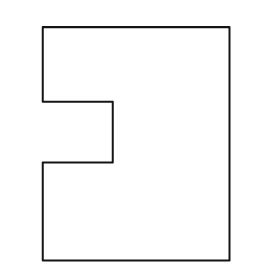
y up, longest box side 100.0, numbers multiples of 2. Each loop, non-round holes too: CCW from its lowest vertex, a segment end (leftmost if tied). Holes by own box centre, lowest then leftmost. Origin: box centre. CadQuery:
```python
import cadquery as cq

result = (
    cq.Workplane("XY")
    .moveTo(-40.0, -50.0)
    .lineTo(40.0, -50.0)
    .lineTo(40.0, 50.0)
    .lineTo(-40.0, 50.0)
    .lineTo(-40.0, 18.0)
    .lineTo(-10.0, 18.0)
    .lineTo(-10.0, -8.0)
    .lineTo(-40.0, -8.0)
    .close()
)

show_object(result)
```